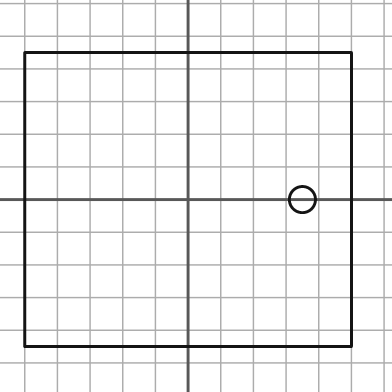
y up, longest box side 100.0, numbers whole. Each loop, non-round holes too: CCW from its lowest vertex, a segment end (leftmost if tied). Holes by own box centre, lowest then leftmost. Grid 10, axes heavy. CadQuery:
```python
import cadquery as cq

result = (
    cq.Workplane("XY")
    .moveTo(-50.0, -45.0)
    .lineTo(50.0, -45.0)
    .lineTo(50.0, 45.0)
    .lineTo(-50.0, 45.0)
    .close()
    .moveTo(35.0, 0.0)
    .circle(4.0)
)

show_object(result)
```